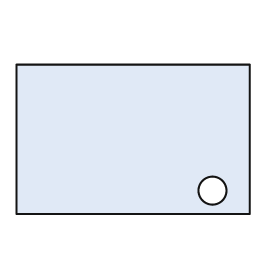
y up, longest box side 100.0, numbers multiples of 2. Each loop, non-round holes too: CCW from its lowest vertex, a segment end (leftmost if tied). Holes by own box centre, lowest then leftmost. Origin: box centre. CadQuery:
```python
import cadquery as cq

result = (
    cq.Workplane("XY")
    .moveTo(-50.0, -32.0)
    .lineTo(50.0, -32.0)
    .lineTo(50.0, 32.0)
    .lineTo(-50.0, 32.0)
    .close()
    .moveTo(34.0, -22.0)
    .circle(6.0)
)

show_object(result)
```